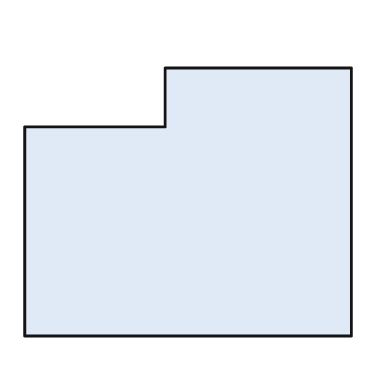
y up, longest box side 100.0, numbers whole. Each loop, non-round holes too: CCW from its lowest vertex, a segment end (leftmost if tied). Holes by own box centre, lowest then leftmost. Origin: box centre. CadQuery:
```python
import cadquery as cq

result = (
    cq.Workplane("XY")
    .moveTo(-50.0, -41.0)
    .lineTo(50.0, -41.0)
    .lineTo(50.0, 41.0)
    .lineTo(-7.0, 41.0)
    .lineTo(-7.0, 23.0)
    .lineTo(-50.0, 23.0)
    .close()
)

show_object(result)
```